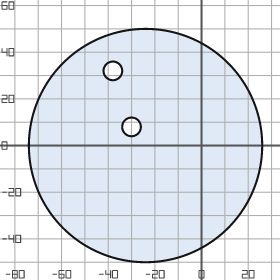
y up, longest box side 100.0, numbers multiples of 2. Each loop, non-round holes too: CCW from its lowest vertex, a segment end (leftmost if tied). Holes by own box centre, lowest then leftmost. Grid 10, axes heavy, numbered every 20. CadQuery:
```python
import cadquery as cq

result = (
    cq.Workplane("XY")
    .moveTo(-24.0, 0.0)
    .circle(50.0)
    .moveTo(-30.0, 8.0)
    .circle(4.0)
    .moveTo(-38.0, 32.0)
    .circle(4.0)
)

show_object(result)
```